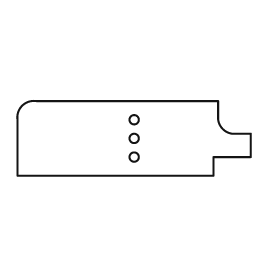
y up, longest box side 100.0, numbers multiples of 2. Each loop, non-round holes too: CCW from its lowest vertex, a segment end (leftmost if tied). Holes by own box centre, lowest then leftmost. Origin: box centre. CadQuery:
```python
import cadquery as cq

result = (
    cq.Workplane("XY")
    .moveTo(-50.0, -16.0)
    .lineTo(34.0, -16.0)
    .lineTo(34.0, -8.0)
    .lineTo(50.0, -8.0)
    .lineTo(50.0, 2.0)
    .lineTo(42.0, 2.0)
    .threePointArc((38.0, 4.0), (36.0, 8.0))
    .lineTo(36.0, 16.0)
    .lineTo(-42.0, 16.0)
    .threePointArc((-48.0, 14.0), (-50.0, 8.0))
    .close()
    .moveTo(0.0, -8.0)
    .circle(2.0)
    .moveTo(0.0, 0.0)
    .circle(2.0)
    .moveTo(0.0, 8.0)
    .circle(2.0)
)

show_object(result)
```